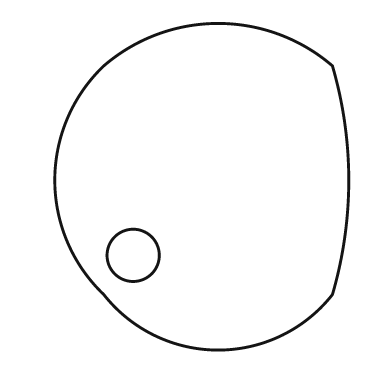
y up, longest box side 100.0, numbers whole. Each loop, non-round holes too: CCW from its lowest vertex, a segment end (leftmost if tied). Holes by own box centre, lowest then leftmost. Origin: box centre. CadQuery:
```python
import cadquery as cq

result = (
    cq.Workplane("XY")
    .moveTo(-30.0, -33.0)
    .threePointArc((5.0, -50.0), (40.0, -33.0))
    .threePointArc((45.0, 2.0), (40.0, 37.0))
    .threePointArc((5.0, 50.0), (-30.0, 37.0))
    .threePointArc((-45.0, 2.0), (-30.0, -33.0))
    .close()
    .moveTo(-21.0, -21.0)
    .circle(8.0)
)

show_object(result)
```